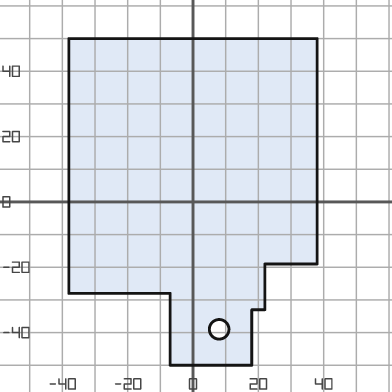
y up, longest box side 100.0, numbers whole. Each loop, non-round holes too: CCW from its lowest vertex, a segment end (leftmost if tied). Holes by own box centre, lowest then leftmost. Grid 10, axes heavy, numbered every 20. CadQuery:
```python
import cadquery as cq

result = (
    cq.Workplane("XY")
    .moveTo(-7.0, -50.0)
    .lineTo(18.0, -50.0)
    .lineTo(18.0, -33.0)
    .lineTo(22.0, -33.0)
    .lineTo(22.0, -19.0)
    .lineTo(38.0, -19.0)
    .lineTo(38.0, 50.0)
    .lineTo(-38.0, 50.0)
    .lineTo(-38.0, -28.0)
    .lineTo(-7.0, -28.0)
    .close()
    .moveTo(8.0, -39.0)
    .circle(3.0)
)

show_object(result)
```